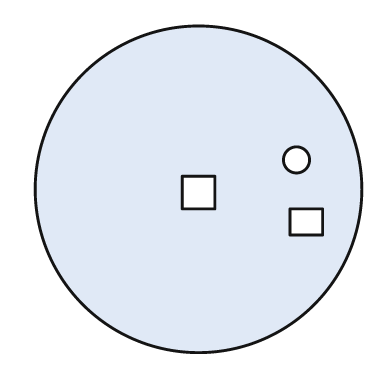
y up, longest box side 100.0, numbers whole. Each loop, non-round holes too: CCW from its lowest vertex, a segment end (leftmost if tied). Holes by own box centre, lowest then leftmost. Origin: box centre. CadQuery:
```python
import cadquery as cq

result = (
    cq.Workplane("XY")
    .moveTo(0.0, 0.0)
    .circle(50.0)
    .moveTo(28.0, -14.0)
    .lineTo(38.0, -14.0)
    .lineTo(38.0, -6.0)
    .lineTo(28.0, -6.0)
    .close()
    .moveTo(-5.0, -6.0)
    .lineTo(5.0, -6.0)
    .lineTo(5.0, 4.0)
    .lineTo(-5.0, 4.0)
    .close()
    .moveTo(30.0, 9.0)
    .circle(4.0)
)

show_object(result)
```